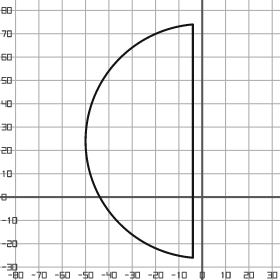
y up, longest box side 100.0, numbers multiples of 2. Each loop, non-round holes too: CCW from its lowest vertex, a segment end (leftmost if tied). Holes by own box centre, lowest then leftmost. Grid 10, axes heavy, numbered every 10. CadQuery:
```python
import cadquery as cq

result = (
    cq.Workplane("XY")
    .moveTo(-4.0, -26.0)
    .lineTo(-4.0, 74.0)
    .threePointArc((-50.0, 24.0), (-4.0, -26.0))
    .close()
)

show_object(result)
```